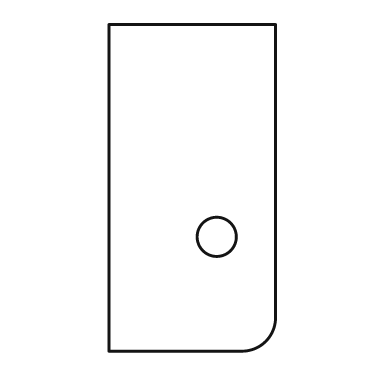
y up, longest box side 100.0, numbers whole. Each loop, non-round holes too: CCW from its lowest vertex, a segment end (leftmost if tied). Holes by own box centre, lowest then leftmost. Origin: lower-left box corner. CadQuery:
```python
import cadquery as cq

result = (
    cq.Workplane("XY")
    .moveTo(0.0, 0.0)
    .lineTo(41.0, 0.0)
    .threePointArc((48.0, 3.0), (51.0, 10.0))
    .lineTo(51.0, 100.0)
    .lineTo(0.0, 100.0)
    .close()
    .moveTo(33.0, 35.0)
    .circle(6.0)
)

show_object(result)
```